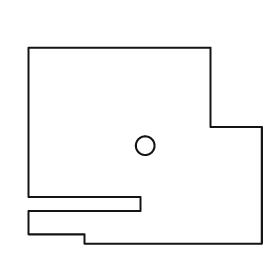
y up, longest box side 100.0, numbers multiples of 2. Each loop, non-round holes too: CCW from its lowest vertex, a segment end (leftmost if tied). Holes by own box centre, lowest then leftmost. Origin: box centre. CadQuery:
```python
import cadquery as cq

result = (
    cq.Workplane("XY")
    .moveTo(-26.0, -42.0)
    .lineTo(50.0, -42.0)
    .lineTo(50.0, 8.0)
    .lineTo(28.0, 8.0)
    .lineTo(28.0, 42.0)
    .lineTo(-50.0, 42.0)
    .lineTo(-50.0, -22.0)
    .lineTo(-2.0, -22.0)
    .lineTo(-2.0, -28.0)
    .lineTo(-50.0, -28.0)
    .lineTo(-50.0, -38.0)
    .lineTo(-26.0, -38.0)
    .close()
    .moveTo(0.0, 0.0)
    .circle(4.0)
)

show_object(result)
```